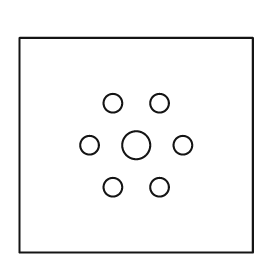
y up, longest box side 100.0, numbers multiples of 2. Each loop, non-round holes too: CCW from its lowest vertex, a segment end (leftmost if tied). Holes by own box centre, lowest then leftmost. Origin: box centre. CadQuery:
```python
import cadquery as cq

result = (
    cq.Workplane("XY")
    .moveTo(-50.0, -46.0)
    .lineTo(50.0, -46.0)
    .lineTo(50.0, 46.0)
    .lineTo(-50.0, 46.0)
    .close()
    .moveTo(-10.0, -18.0)
    .circle(4.0)
    .moveTo(10.0, -18.0)
    .circle(4.0)
    .moveTo(-20.0, 0.0)
    .circle(4.0)
    .moveTo(0.0, 0.0)
    .circle(6.0)
    .moveTo(20.0, 0.0)
    .circle(4.0)
    .moveTo(-10.0, 18.0)
    .circle(4.0)
    .moveTo(10.0, 18.0)
    .circle(4.0)
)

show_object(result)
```